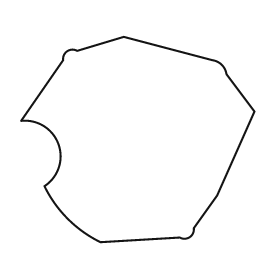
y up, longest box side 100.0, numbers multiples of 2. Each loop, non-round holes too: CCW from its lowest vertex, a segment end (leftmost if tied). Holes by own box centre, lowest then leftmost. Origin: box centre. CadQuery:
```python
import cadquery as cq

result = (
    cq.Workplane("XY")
    .moveTo(-16.0, -44.0)
    .lineTo(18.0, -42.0)
    .threePointArc((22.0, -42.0), (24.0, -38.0))
    .lineTo(34.0, -24.0)
    .lineTo(50.0, 12.0)
    .lineTo(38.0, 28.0)
    .threePointArc((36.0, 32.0), (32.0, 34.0))
    .lineTo(-6.0, 44.0)
    .lineTo(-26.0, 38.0)
    .threePointArc((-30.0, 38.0), (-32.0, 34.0))
    .lineTo(-50.0, 8.0)
    .threePointArc((-34.0, -2.0), (-40.0, -20.0))
    .threePointArc((-30.0, -34.0), (-16.0, -44.0))
    .close()
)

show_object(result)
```